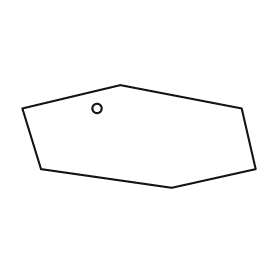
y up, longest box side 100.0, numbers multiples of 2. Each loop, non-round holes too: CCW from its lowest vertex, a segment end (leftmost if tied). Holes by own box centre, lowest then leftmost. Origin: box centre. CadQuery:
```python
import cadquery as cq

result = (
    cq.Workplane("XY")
    .moveTo(14.0, -22.0)
    .lineTo(50.0, -14.0)
    .lineTo(44.0, 12.0)
    .lineTo(-8.0, 22.0)
    .lineTo(-50.0, 12.0)
    .lineTo(-42.0, -14.0)
    .close()
    .moveTo(-18.0, 12.0)
    .circle(2.0)
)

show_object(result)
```